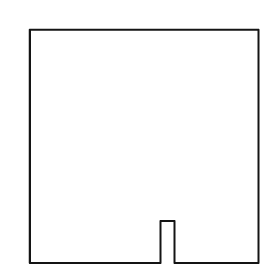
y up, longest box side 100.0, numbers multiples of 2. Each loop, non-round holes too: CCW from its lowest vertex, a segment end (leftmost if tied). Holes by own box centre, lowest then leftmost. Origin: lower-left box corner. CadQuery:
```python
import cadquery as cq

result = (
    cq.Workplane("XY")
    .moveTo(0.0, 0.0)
    .lineTo(56.0, 0.0)
    .lineTo(56.0, 18.0)
    .lineTo(62.0, 18.0)
    .lineTo(62.0, 0.0)
    .lineTo(98.0, 0.0)
    .lineTo(98.0, 100.0)
    .lineTo(0.0, 100.0)
    .close()
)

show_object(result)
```